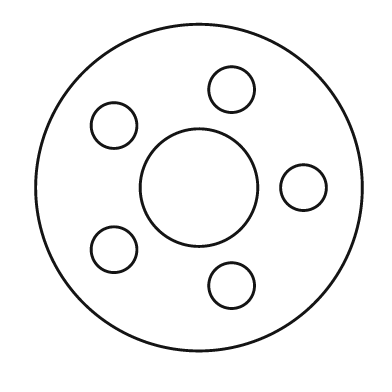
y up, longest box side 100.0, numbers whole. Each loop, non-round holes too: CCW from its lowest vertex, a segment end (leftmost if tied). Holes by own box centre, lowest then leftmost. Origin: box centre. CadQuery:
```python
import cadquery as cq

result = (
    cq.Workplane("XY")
    .moveTo(0.0, 0.0)
    .circle(50.0)
    .moveTo(10.0, -30.0)
    .circle(7.0)
    .moveTo(-26.0, -19.0)
    .circle(7.0)
    .moveTo(0.0, 0.0)
    .circle(18.0)
    .moveTo(32.0, 0.0)
    .circle(7.0)
    .moveTo(-26.0, 19.0)
    .circle(7.0)
    .moveTo(10.0, 30.0)
    .circle(7.0)
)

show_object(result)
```